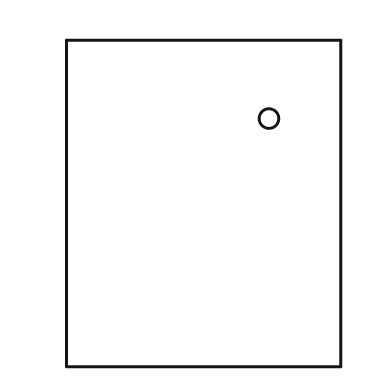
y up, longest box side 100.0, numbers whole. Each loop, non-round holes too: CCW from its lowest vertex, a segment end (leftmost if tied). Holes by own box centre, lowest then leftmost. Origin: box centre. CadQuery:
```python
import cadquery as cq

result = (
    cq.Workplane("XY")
    .moveTo(-42.0, -50.0)
    .lineTo(42.0, -50.0)
    .lineTo(42.0, 50.0)
    .lineTo(-42.0, 50.0)
    .close()
    .moveTo(20.0, 26.0)
    .circle(3.0)
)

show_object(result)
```